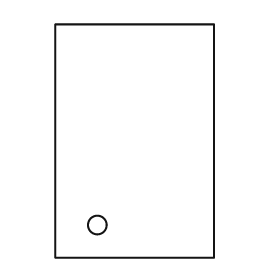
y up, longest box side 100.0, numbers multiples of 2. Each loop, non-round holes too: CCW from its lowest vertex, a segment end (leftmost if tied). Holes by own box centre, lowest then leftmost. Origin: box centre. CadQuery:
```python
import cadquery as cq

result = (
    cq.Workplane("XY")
    .moveTo(-34.0, -50.0)
    .lineTo(34.0, -50.0)
    .lineTo(34.0, 50.0)
    .lineTo(-34.0, 50.0)
    .close()
    .moveTo(-16.0, -36.0)
    .circle(4.0)
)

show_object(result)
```